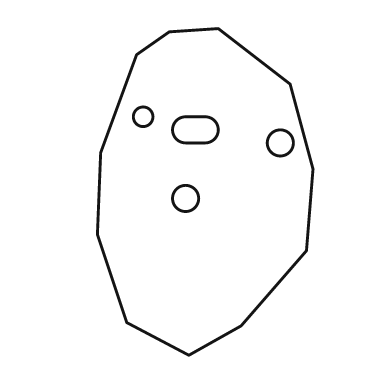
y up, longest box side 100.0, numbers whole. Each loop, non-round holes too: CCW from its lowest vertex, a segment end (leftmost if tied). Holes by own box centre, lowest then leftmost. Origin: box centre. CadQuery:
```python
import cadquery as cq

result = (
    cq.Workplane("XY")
    .moveTo(-5.0, -50.0)
    .lineTo(11.0, -41.0)
    .lineTo(31.0, -18.0)
    .lineTo(33.0, 7.0)
    .lineTo(26.0, 33.0)
    .lineTo(4.0, 50.0)
    .lineTo(-11.0, 49.0)
    .lineTo(-21.0, 42.0)
    .lineTo(-32.0, 12.0)
    .lineTo(-33.0, -13.0)
    .lineTo(-24.0, -40.0)
    .close()
    .moveTo(-6.0, -2.0)
    .circle(4.0)
    .moveTo(23.0, 15.0)
    .circle(4.0)
    .moveTo(-6.0, 15.0)
    .lineTo(0.0, 15.0)
    .threePointArc((4.0, 19.0), (0.0, 23.0))
    .lineTo(-6.0, 23.0)
    .threePointArc((-10.0, 19.0), (-6.0, 15.0))
    .close()
    .moveTo(-19.0, 23.0)
    .circle(3.0)
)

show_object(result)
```